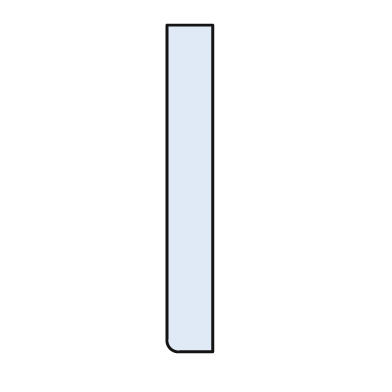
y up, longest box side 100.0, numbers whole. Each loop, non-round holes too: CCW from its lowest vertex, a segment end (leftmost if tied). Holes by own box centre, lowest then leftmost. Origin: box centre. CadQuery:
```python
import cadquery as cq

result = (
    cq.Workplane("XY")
    .moveTo(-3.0, -50.0)
    .lineTo(7.0, -50.0)
    .lineTo(7.0, 50.0)
    .lineTo(-7.0, 50.0)
    .lineTo(-7.0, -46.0)
    .threePointArc((-6.0, -49.0), (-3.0, -50.0))
    .close()
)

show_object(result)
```